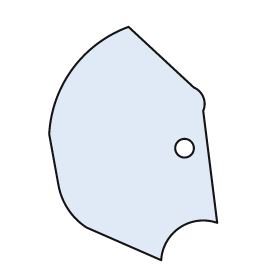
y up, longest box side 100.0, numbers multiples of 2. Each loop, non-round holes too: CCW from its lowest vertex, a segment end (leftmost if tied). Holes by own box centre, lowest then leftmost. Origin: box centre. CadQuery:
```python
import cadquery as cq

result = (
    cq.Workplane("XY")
    .moveTo(12.0, -50.0)
    .threePointArc((20.0, -36.0), (36.0, -34.0))
    .lineTo(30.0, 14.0)
    .threePointArc((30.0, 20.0), (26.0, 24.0))
    .lineTo(-2.0, 50.0)
    .threePointArc((-26.0, 32.0), (-36.0, 4.0))
    .lineTo(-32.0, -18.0)
    .threePointArc((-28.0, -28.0), (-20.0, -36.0))
    .close()
    .moveTo(22.0, -2.0)
    .circle(4.0)
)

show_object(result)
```